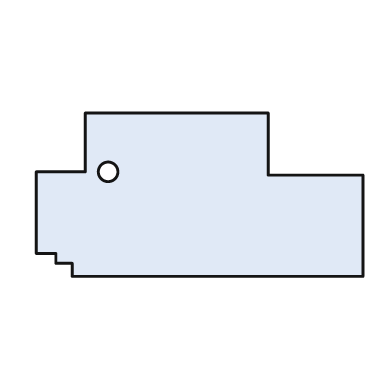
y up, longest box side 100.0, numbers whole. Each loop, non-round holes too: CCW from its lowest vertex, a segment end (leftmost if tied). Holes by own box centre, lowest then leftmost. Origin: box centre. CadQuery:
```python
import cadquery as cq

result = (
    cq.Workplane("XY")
    .moveTo(-39.0, -25.0)
    .lineTo(50.0, -25.0)
    .lineTo(50.0, 6.0)
    .lineTo(21.0, 6.0)
    .lineTo(21.0, 25.0)
    .lineTo(-35.0, 25.0)
    .lineTo(-35.0, 7.0)
    .lineTo(-50.0, 7.0)
    .lineTo(-50.0, -18.0)
    .lineTo(-44.0, -18.0)
    .lineTo(-44.0, -21.0)
    .lineTo(-39.0, -21.0)
    .close()
    .moveTo(-28.0, 7.0)
    .circle(3.0)
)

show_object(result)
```